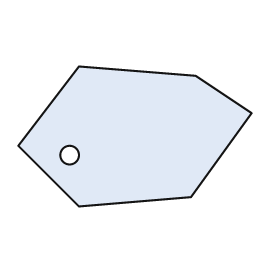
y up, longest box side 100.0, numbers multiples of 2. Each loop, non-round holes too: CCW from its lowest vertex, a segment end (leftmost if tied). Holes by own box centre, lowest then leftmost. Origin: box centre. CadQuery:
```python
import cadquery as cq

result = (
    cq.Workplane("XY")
    .moveTo(-24.0, -30.0)
    .lineTo(24.0, -26.0)
    .lineTo(50.0, 10.0)
    .lineTo(26.0, 26.0)
    .lineTo(-24.0, 30.0)
    .lineTo(-50.0, -4.0)
    .close()
    .moveTo(-28.0, -8.0)
    .circle(4.0)
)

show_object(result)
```